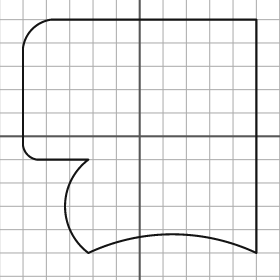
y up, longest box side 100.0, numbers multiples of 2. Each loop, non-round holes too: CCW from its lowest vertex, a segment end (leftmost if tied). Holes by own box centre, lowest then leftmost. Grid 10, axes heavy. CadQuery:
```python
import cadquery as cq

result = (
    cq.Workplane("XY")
    .moveTo(-22.0, -50.0)
    .threePointArc((14.0, -42.0), (50.0, -50.0))
    .lineTo(50.0, 50.0)
    .lineTo(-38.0, 50.0)
    .threePointArc((-46.0, 46.0), (-50.0, 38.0))
    .lineTo(-50.0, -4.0)
    .threePointArc((-48.0, -8.0), (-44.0, -10.0))
    .lineTo(-22.0, -10.0)
    .threePointArc((-32.0, -30.0), (-22.0, -50.0))
    .close()
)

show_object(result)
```